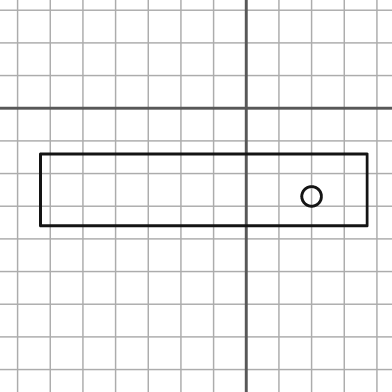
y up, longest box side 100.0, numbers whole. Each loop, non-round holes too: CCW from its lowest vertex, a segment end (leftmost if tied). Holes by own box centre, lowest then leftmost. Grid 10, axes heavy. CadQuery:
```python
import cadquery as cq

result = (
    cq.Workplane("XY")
    .moveTo(-63.0, -36.0)
    .lineTo(37.0, -36.0)
    .lineTo(37.0, -14.0)
    .lineTo(-63.0, -14.0)
    .close()
    .moveTo(20.0, -27.0)
    .circle(3.0)
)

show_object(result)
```